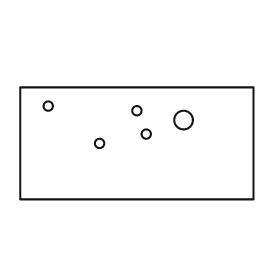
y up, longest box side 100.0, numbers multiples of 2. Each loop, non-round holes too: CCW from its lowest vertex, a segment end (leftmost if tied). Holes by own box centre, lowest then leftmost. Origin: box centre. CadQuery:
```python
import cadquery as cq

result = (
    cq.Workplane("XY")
    .moveTo(-50.0, -24.0)
    .lineTo(50.0, -24.0)
    .lineTo(50.0, 24.0)
    .lineTo(-50.0, 24.0)
    .close()
    .moveTo(-16.0, 0.0)
    .circle(2.0)
    .moveTo(4.0, 4.0)
    .circle(2.0)
    .moveTo(20.0, 10.0)
    .circle(4.0)
    .moveTo(0.0, 14.0)
    .circle(2.0)
    .moveTo(-38.0, 16.0)
    .circle(2.0)
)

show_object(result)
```